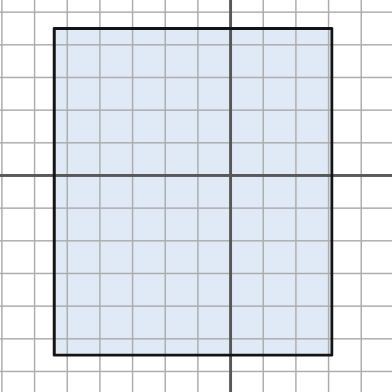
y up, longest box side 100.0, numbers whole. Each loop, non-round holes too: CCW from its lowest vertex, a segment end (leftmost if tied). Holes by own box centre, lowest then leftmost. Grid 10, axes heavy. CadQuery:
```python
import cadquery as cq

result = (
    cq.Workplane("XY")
    .moveTo(-54.0, -55.0)
    .lineTo(31.0, -55.0)
    .lineTo(31.0, 45.0)
    .lineTo(-54.0, 45.0)
    .close()
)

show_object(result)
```